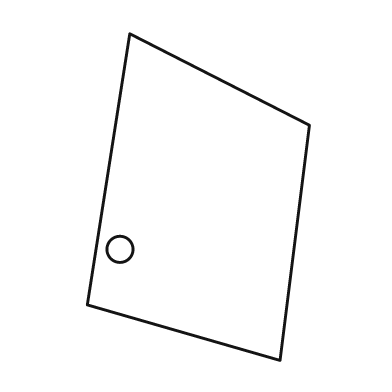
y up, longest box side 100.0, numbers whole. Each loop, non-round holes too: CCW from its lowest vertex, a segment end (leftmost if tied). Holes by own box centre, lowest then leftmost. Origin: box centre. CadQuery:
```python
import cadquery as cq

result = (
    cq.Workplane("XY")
    .moveTo(25.0, -50.0)
    .lineTo(34.0, 22.0)
    .lineTo(-21.0, 50.0)
    .lineTo(-34.0, -33.0)
    .close()
    .moveTo(-24.0, -16.0)
    .circle(4.0)
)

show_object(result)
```